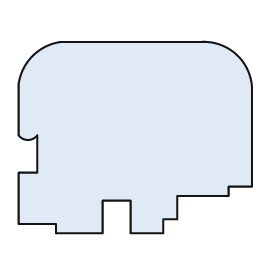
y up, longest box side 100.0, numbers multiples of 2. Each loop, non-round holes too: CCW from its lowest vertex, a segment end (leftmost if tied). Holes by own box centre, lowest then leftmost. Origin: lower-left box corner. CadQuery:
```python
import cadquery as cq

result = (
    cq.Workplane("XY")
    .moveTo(16.0, 0.0)
    .lineTo(36.0, 0.0)
    .lineTo(36.0, 14.0)
    .lineTo(48.0, 14.0)
    .lineTo(48.0, 0.0)
    .lineTo(62.0, 0.0)
    .lineTo(62.0, 6.0)
    .lineTo(68.0, 6.0)
    .lineTo(68.0, 16.0)
    .lineTo(90.0, 16.0)
    .lineTo(90.0, 20.0)
    .lineTo(100.0, 20.0)
    .lineTo(100.0, 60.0)
    .threePointArc((94.0, 76.0), (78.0, 82.0))
    .lineTo(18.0, 82.0)
    .threePointArc((6.0, 76.0), (0.0, 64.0))
    .lineTo(0.0, 42.0)
    .threePointArc((4.0, 40.0), (8.0, 42.0))
    .lineTo(8.0, 26.0)
    .lineTo(0.0, 26.0)
    .lineTo(0.0, 4.0)
    .lineTo(16.0, 4.0)
    .close()
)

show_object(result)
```